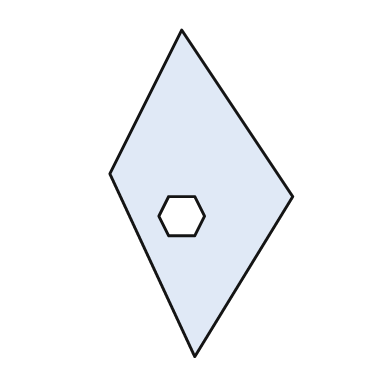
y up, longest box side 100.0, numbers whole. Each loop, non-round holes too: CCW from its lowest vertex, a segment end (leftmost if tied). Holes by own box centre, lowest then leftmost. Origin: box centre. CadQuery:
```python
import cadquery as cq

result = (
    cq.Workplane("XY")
    .moveTo(-2.0, -50.0)
    .lineTo(28.0, -1.0)
    .lineTo(-6.0, 50.0)
    .lineTo(-28.0, 6.0)
    .close()
    .moveTo(-10.0, -13.0)
    .lineTo(-2.0, -13.0)
    .lineTo(1.0, -7.0)
    .lineTo(-2.0, -1.0)
    .lineTo(-10.0, -1.0)
    .lineTo(-13.0, -7.0)
    .close()
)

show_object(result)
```